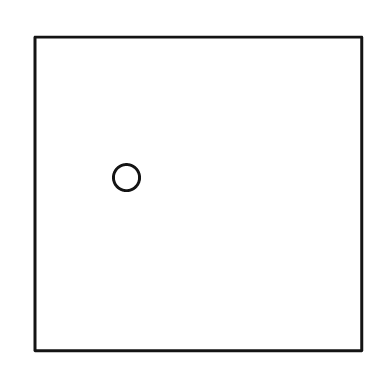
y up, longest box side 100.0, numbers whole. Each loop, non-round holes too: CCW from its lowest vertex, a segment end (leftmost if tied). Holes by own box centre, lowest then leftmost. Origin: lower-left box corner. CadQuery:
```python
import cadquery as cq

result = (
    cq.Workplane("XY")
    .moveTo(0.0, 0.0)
    .lineTo(100.0, 0.0)
    .lineTo(100.0, 96.0)
    .lineTo(0.0, 96.0)
    .close()
    .moveTo(28.0, 53.0)
    .circle(4.0)
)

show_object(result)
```